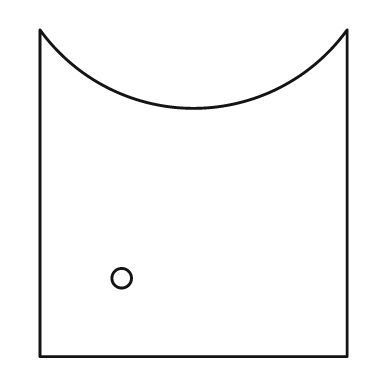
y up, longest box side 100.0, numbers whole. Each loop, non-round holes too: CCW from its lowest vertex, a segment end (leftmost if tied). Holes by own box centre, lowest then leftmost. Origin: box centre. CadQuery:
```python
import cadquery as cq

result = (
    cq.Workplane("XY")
    .moveTo(-47.0, -50.0)
    .lineTo(47.0, -50.0)
    .lineTo(47.0, 50.0)
    .threePointArc((0.0, 26.0), (-47.0, 50.0))
    .close()
    .moveTo(-22.0, -26.0)
    .circle(3.0)
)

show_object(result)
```